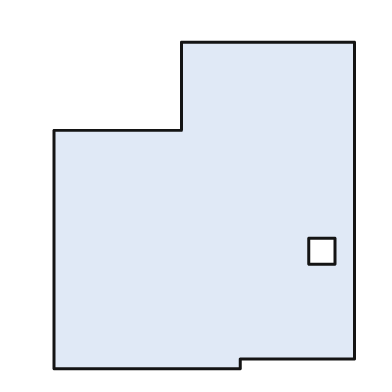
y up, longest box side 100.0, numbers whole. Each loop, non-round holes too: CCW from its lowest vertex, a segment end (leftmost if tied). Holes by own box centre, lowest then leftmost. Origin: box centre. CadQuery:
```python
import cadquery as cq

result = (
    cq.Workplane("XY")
    .moveTo(-46.0, -50.0)
    .lineTo(11.0, -50.0)
    .lineTo(11.0, -47.0)
    .lineTo(46.0, -47.0)
    .lineTo(46.0, 50.0)
    .lineTo(-7.0, 50.0)
    .lineTo(-7.0, 23.0)
    .lineTo(-46.0, 23.0)
    .close()
    .moveTo(32.0, -18.0)
    .lineTo(40.0, -18.0)
    .lineTo(40.0, -10.0)
    .lineTo(32.0, -10.0)
    .close()
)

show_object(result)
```